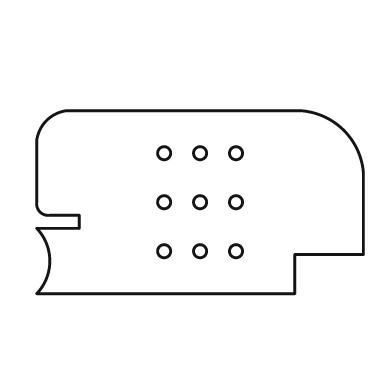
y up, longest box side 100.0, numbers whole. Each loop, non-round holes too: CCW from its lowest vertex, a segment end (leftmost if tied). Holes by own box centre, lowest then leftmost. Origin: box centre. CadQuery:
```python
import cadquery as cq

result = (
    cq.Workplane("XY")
    .moveTo(-50.0, -28.0)
    .lineTo(29.0, -28.0)
    .lineTo(29.0, -16.0)
    .lineTo(50.0, -16.0)
    .lineTo(50.0, 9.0)
    .threePointArc((44.0, 22.0), (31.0, 28.0))
    .lineTo(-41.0, 28.0)
    .threePointArc((-47.0, 25.0), (-50.0, 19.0))
    .lineTo(-50.0, 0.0)
    .threePointArc((-49.0, -3.0), (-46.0, -4.0))
    .lineTo(-37.0, -4.0)
    .lineTo(-37.0, -8.0)
    .lineTo(-50.0, -8.0)
    .threePointArc((-46.0, -18.0), (-50.0, -28.0))
    .close()
    .moveTo(-11.0, -15.0)
    .circle(2.0)
    .moveTo(0.0, -15.0)
    .circle(2.0)
    .moveTo(11.0, -15.0)
    .circle(2.0)
    .moveTo(-11.0, 0.0)
    .circle(2.0)
    .moveTo(0.0, 0.0)
    .circle(2.0)
    .moveTo(11.0, 0.0)
    .circle(2.0)
    .moveTo(-11.0, 15.0)
    .circle(2.0)
    .moveTo(0.0, 15.0)
    .circle(2.0)
    .moveTo(11.0, 15.0)
    .circle(2.0)
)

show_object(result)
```